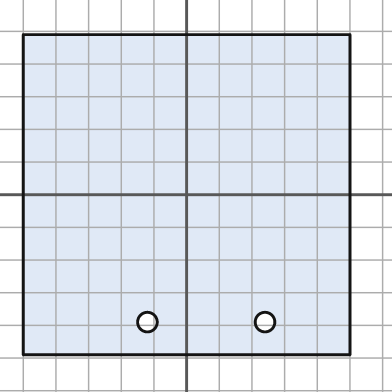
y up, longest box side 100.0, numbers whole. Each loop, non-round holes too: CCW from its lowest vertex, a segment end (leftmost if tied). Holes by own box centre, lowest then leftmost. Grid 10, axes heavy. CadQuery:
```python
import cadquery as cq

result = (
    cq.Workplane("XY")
    .moveTo(-50.0, -49.0)
    .lineTo(50.0, -49.0)
    .lineTo(50.0, 49.0)
    .lineTo(-50.0, 49.0)
    .close()
    .moveTo(-12.0, -39.0)
    .circle(3.0)
    .moveTo(24.0, -39.0)
    .circle(3.0)
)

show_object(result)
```